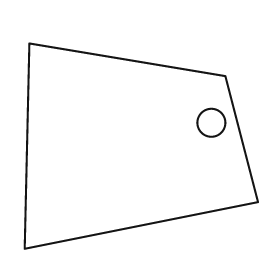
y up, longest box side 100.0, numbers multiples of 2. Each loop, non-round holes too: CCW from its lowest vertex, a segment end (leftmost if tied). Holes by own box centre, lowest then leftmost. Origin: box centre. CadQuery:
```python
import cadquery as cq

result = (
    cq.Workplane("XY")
    .moveTo(-50.0, -44.0)
    .lineTo(50.0, -24.0)
    .lineTo(36.0, 30.0)
    .lineTo(-48.0, 44.0)
    .close()
    .moveTo(30.0, 10.0)
    .circle(6.0)
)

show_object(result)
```